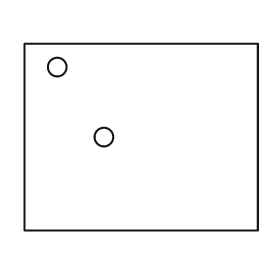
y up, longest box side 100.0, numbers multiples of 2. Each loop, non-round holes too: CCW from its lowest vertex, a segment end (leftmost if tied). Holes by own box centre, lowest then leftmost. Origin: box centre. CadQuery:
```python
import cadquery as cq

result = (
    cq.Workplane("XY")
    .moveTo(-50.0, -40.0)
    .lineTo(50.0, -40.0)
    .lineTo(50.0, 40.0)
    .lineTo(-50.0, 40.0)
    .close()
    .moveTo(-16.0, 0.0)
    .circle(4.0)
    .moveTo(-36.0, 30.0)
    .circle(4.0)
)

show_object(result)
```